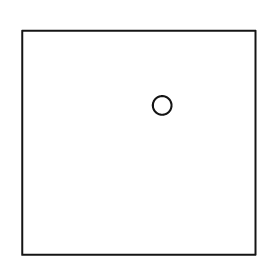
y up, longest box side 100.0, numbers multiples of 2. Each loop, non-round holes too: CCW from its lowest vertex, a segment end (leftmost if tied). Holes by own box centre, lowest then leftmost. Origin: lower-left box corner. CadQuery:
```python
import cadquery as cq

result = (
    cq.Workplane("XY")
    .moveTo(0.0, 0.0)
    .lineTo(100.0, 0.0)
    .lineTo(100.0, 96.0)
    .lineTo(0.0, 96.0)
    .close()
    .moveTo(60.0, 64.0)
    .circle(4.0)
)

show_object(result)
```